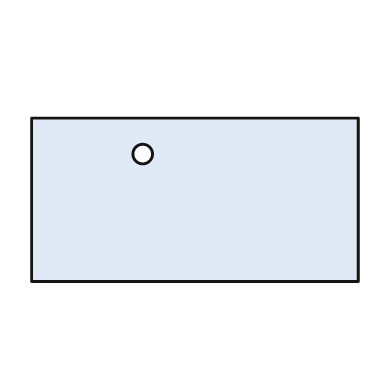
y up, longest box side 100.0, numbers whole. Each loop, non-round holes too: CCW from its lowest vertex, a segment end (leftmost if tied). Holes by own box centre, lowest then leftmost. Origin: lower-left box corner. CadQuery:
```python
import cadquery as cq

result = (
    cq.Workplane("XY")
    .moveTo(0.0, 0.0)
    .lineTo(100.0, 0.0)
    .lineTo(100.0, 50.0)
    .lineTo(0.0, 50.0)
    .close()
    .moveTo(34.0, 39.0)
    .circle(3.0)
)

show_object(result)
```